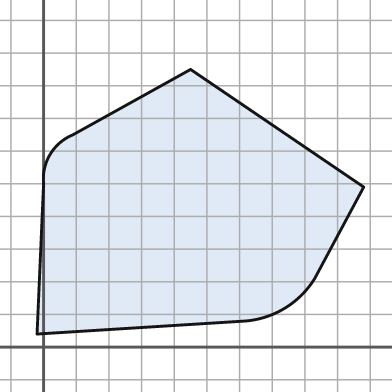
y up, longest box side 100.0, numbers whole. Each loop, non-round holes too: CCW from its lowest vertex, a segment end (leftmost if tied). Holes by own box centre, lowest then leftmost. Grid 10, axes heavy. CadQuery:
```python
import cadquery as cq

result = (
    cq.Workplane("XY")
    .moveTo(-2.0, 4.0)
    .lineTo(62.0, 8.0)
    .threePointArc((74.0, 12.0), (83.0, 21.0))
    .lineTo(98.0, 49.0)
    .lineTo(45.0, 85.0)
    .lineTo(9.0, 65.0)
    .threePointArc((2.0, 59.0), (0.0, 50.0))
    .close()
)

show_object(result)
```